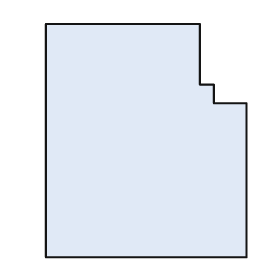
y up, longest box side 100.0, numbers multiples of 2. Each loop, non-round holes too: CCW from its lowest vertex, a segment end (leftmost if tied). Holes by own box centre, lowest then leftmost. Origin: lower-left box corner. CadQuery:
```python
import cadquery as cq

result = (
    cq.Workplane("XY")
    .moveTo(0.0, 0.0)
    .lineTo(86.0, 0.0)
    .lineTo(86.0, 66.0)
    .lineTo(72.0, 66.0)
    .lineTo(72.0, 74.0)
    .lineTo(66.0, 74.0)
    .lineTo(66.0, 100.0)
    .lineTo(0.0, 100.0)
    .close()
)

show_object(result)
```